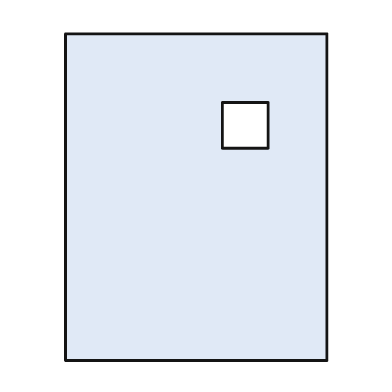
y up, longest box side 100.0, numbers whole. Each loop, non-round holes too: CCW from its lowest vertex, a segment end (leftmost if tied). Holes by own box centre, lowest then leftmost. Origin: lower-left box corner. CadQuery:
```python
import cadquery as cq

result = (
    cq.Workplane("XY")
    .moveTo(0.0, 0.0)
    .lineTo(80.0, 0.0)
    .lineTo(80.0, 100.0)
    .lineTo(0.0, 100.0)
    .close()
    .moveTo(48.0, 65.0)
    .lineTo(62.0, 65.0)
    .lineTo(62.0, 79.0)
    .lineTo(48.0, 79.0)
    .close()
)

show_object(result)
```